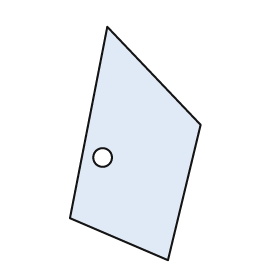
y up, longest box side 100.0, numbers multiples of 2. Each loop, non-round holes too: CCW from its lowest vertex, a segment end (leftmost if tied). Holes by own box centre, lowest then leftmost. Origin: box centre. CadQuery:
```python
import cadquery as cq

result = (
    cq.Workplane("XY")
    .moveTo(14.0, -50.0)
    .lineTo(28.0, 8.0)
    .lineTo(-12.0, 50.0)
    .lineTo(-28.0, -32.0)
    .close()
    .moveTo(-14.0, -6.0)
    .circle(4.0)
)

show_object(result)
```